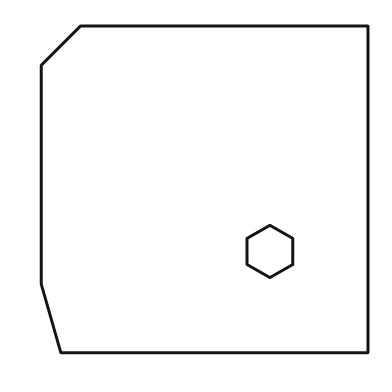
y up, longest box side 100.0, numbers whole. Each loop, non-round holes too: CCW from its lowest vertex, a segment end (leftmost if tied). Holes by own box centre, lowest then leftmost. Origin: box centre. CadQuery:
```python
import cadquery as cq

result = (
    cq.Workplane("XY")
    .moveTo(-44.0, -50.0)
    .lineTo(50.0, -50.0)
    .lineTo(50.0, 50.0)
    .lineTo(-38.0, 50.0)
    .lineTo(-50.0, 38.0)
    .lineTo(-50.0, -29.0)
    .close()
    .moveTo(20.0, -27.0)
    .lineTo(27.0, -23.0)
    .lineTo(27.0, -15.0)
    .lineTo(20.0, -11.0)
    .lineTo(13.0, -15.0)
    .lineTo(13.0, -23.0)
    .close()
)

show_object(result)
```